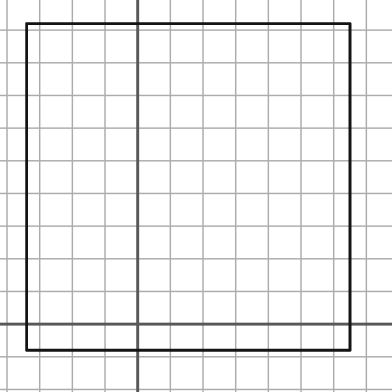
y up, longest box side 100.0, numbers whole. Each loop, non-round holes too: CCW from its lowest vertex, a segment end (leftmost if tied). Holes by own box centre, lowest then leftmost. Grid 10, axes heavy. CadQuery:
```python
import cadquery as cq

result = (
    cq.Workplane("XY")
    .moveTo(-34.0, -8.0)
    .lineTo(65.0, -8.0)
    .lineTo(65.0, 92.0)
    .lineTo(-34.0, 92.0)
    .close()
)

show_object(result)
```